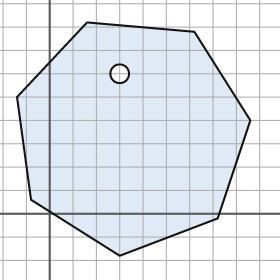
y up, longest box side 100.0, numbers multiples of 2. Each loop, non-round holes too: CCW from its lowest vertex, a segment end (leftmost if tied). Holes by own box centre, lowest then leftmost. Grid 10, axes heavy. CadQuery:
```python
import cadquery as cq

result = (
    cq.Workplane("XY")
    .moveTo(30.0, -18.0)
    .lineTo(72.0, -2.0)
    .lineTo(86.0, 40.0)
    .lineTo(62.0, 78.0)
    .lineTo(16.0, 82.0)
    .lineTo(-14.0, 50.0)
    .lineTo(-8.0, 6.0)
    .close()
    .moveTo(30.0, 60.0)
    .circle(4.0)
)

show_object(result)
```